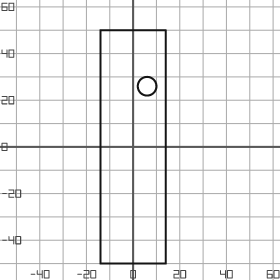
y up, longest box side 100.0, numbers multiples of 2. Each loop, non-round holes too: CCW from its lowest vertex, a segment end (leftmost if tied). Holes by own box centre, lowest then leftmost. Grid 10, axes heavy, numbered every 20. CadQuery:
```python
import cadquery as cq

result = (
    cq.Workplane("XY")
    .moveTo(-14.0, -50.0)
    .lineTo(14.0, -50.0)
    .lineTo(14.0, 50.0)
    .lineTo(-14.0, 50.0)
    .close()
    .moveTo(6.0, 26.0)
    .circle(4.0)
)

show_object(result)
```